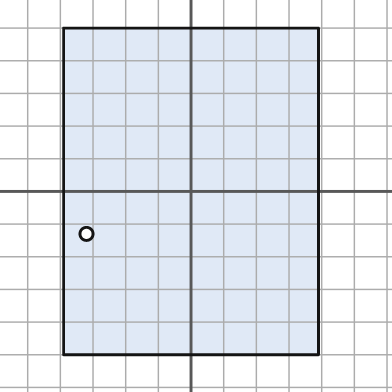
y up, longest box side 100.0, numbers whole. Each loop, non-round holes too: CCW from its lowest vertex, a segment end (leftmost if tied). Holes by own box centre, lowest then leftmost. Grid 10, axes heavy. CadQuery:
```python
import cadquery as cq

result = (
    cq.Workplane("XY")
    .moveTo(-39.0, -50.0)
    .lineTo(39.0, -50.0)
    .lineTo(39.0, 50.0)
    .lineTo(-39.0, 50.0)
    .close()
    .moveTo(-32.0, -13.0)
    .circle(2.0)
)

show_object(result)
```